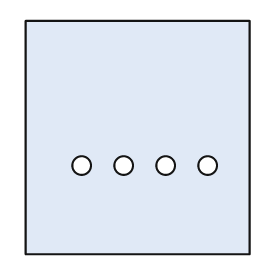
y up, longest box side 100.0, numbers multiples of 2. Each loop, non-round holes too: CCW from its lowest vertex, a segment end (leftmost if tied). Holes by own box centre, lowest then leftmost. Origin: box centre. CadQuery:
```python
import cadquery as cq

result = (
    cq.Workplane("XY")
    .moveTo(-48.0, -50.0)
    .lineTo(48.0, -50.0)
    .lineTo(48.0, 50.0)
    .lineTo(-48.0, 50.0)
    .close()
    .moveTo(-24.0, -12.0)
    .circle(4.0)
    .moveTo(-6.0, -12.0)
    .circle(4.0)
    .moveTo(12.0, -12.0)
    .circle(4.0)
    .moveTo(30.0, -12.0)
    .circle(4.0)
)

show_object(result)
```